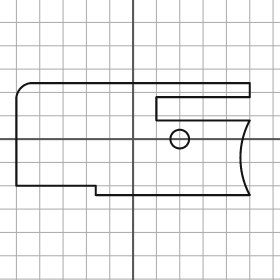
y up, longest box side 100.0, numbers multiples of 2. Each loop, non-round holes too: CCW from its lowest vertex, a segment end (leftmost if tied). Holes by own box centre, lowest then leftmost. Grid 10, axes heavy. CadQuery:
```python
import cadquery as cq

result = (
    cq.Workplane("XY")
    .moveTo(-16.0, -24.0)
    .lineTo(50.0, -24.0)
    .threePointArc((46.0, -8.0), (50.0, 8.0))
    .lineTo(10.0, 8.0)
    .lineTo(10.0, 18.0)
    .lineTo(50.0, 18.0)
    .lineTo(50.0, 24.0)
    .lineTo(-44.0, 24.0)
    .threePointArc((-48.0, 22.0), (-50.0, 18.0))
    .lineTo(-50.0, -20.0)
    .lineTo(-16.0, -20.0)
    .close()
    .moveTo(20.0, 0.0)
    .circle(4.0)
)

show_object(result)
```